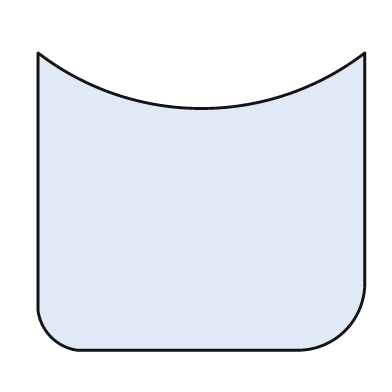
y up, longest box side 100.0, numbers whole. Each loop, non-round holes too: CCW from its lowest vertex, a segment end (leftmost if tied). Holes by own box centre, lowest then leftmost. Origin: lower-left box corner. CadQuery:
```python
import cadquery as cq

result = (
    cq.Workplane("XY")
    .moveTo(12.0, 0.0)
    .lineTo(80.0, 0.0)
    .threePointArc((94.0, 6.0), (100.0, 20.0))
    .lineTo(100.0, 91.0)
    .threePointArc((50.0, 74.0), (0.0, 91.0))
    .lineTo(0.0, 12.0)
    .threePointArc((4.0, 4.0), (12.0, 0.0))
    .close()
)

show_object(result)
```